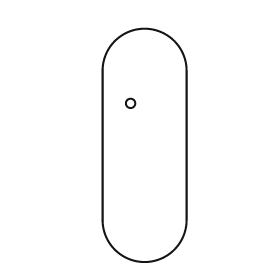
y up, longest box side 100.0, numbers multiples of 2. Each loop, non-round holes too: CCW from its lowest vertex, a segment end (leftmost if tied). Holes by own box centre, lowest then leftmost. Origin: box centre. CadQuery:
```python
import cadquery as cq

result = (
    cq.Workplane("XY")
    .moveTo(-18.0, -32.0)
    .threePointArc((0.0, -50.0), (18.0, -32.0))
    .lineTo(18.0, 32.0)
    .threePointArc((0.0, 50.0), (-18.0, 32.0))
    .close()
    .moveTo(-6.0, 18.0)
    .circle(2.0)
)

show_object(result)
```